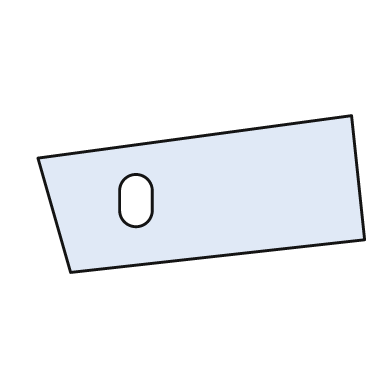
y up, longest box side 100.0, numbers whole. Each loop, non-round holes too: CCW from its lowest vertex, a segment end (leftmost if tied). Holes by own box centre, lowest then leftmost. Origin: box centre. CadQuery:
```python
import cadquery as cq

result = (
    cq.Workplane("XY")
    .moveTo(-40.0, -24.0)
    .lineTo(50.0, -14.0)
    .lineTo(46.0, 24.0)
    .lineTo(-50.0, 11.0)
    .close()
    .moveTo(-25.0, -5.0)
    .threePointArc((-20.0, -10.0), (-15.0, -5.0))
    .lineTo(-15.0, 1.0)
    .threePointArc((-20.0, 6.0), (-25.0, 1.0))
    .close()
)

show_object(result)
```